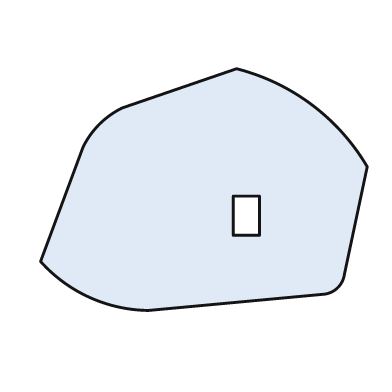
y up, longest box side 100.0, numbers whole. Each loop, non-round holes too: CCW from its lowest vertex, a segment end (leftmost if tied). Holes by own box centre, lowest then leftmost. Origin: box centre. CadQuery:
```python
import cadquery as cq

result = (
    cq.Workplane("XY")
    .moveTo(-17.0, -37.0)
    .lineTo(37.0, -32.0)
    .threePointArc((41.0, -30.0), (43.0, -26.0))
    .lineTo(50.0, 7.0)
    .threePointArc((33.0, 26.0), (10.0, 37.0))
    .lineTo(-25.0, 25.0)
    .threePointArc((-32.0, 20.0), (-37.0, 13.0))
    .lineTo(-50.0, -22.0)
    .threePointArc((-35.0, -33.0), (-17.0, -37.0))
    .close()
    .moveTo(9.0, -14.0)
    .lineTo(17.0, -14.0)
    .lineTo(17.0, -2.0)
    .lineTo(9.0, -2.0)
    .close()
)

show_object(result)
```